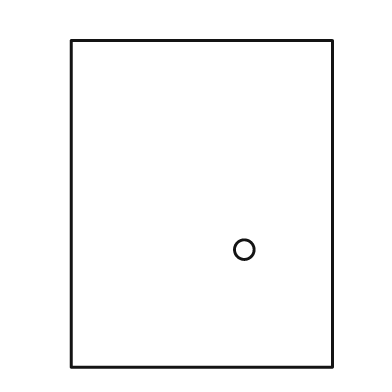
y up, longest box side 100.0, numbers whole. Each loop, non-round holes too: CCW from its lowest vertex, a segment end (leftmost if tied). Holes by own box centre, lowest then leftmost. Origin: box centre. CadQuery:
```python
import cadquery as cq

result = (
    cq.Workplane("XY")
    .moveTo(-40.0, -50.0)
    .lineTo(40.0, -50.0)
    .lineTo(40.0, 50.0)
    .lineTo(-40.0, 50.0)
    .close()
    .moveTo(13.0, -14.0)
    .circle(3.0)
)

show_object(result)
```